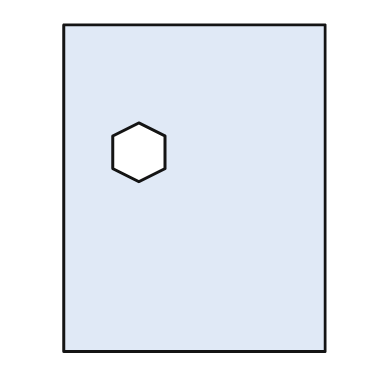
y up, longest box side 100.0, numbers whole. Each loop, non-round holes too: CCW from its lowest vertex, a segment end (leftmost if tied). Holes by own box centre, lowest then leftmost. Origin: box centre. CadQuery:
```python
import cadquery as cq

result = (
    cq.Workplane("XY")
    .moveTo(-40.0, -50.0)
    .lineTo(40.0, -50.0)
    .lineTo(40.0, 50.0)
    .lineTo(-40.0, 50.0)
    .close()
    .moveTo(-17.0, 2.0)
    .lineTo(-9.0, 6.0)
    .lineTo(-9.0, 16.0)
    .lineTo(-17.0, 20.0)
    .lineTo(-25.0, 16.0)
    .lineTo(-25.0, 6.0)
    .close()
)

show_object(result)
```